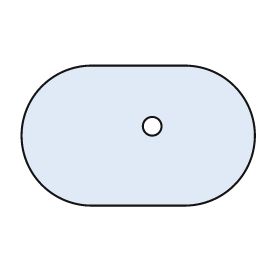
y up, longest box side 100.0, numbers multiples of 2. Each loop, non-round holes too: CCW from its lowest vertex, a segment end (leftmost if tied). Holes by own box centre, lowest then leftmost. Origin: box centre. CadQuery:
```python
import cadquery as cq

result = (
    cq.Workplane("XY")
    .moveTo(-20.0, -30.0)
    .lineTo(20.0, -30.0)
    .threePointArc((50.0, 0.0), (20.0, 30.0))
    .lineTo(-20.0, 30.0)
    .threePointArc((-50.0, 0.0), (-20.0, -30.0))
    .close()
    .moveTo(6.0, 4.0)
    .circle(4.0)
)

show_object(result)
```